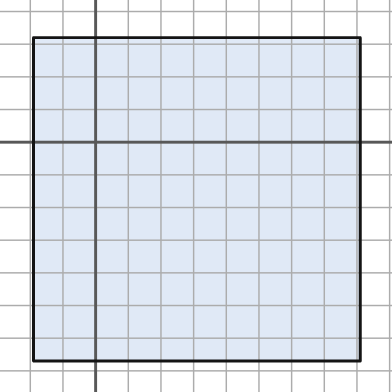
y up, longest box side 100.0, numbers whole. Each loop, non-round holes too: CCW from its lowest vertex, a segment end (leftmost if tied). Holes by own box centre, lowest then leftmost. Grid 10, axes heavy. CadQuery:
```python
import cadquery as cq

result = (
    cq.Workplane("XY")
    .moveTo(-19.0, -67.0)
    .lineTo(81.0, -67.0)
    .lineTo(81.0, 32.0)
    .lineTo(-19.0, 32.0)
    .close()
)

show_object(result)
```